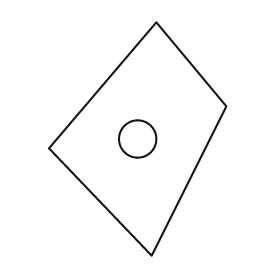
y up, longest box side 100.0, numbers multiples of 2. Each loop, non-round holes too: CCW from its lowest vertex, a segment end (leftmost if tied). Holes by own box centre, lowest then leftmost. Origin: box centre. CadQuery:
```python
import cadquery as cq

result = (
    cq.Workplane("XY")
    .moveTo(6.0, -50.0)
    .lineTo(38.0, 14.0)
    .lineTo(8.0, 50.0)
    .lineTo(-38.0, -4.0)
    .close()
    .moveTo(0.0, 0.0)
    .circle(8.0)
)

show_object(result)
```